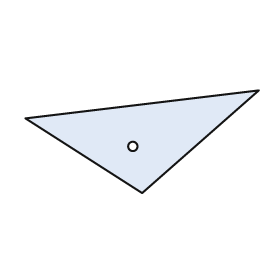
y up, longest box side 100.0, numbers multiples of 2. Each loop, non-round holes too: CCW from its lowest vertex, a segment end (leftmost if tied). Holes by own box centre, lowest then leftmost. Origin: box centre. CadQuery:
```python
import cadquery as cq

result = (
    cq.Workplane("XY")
    .moveTo(0.0, -22.0)
    .lineTo(50.0, 22.0)
    .lineTo(-50.0, 10.0)
    .close()
    .moveTo(-4.0, -2.0)
    .circle(2.0)
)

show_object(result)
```